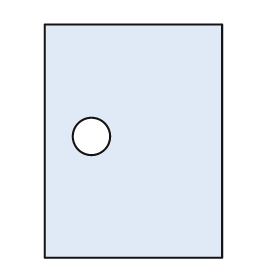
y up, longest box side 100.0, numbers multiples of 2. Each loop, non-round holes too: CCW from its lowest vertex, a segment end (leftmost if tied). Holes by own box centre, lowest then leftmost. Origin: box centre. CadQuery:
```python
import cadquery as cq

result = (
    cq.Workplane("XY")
    .moveTo(-38.0, -50.0)
    .lineTo(38.0, -50.0)
    .lineTo(38.0, 50.0)
    .lineTo(-38.0, 50.0)
    .close()
    .moveTo(-18.0, 2.0)
    .circle(8.0)
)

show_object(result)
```